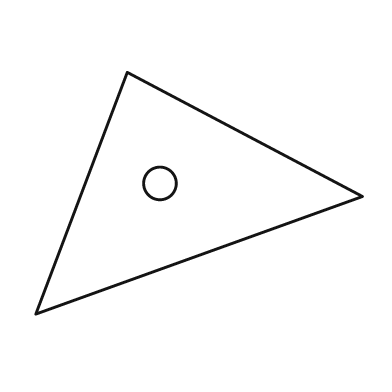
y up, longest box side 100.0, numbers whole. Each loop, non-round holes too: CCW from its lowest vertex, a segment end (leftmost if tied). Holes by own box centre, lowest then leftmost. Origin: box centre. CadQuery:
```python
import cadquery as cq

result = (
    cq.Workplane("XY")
    .moveTo(-50.0, -37.0)
    .lineTo(50.0, -1.0)
    .lineTo(-22.0, 37.0)
    .close()
    .moveTo(-12.0, 3.0)
    .circle(5.0)
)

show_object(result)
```